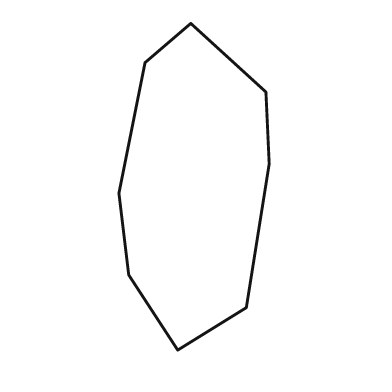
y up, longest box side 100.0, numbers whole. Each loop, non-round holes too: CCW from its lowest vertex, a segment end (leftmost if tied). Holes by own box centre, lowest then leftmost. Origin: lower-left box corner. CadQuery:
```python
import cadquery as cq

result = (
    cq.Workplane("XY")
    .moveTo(18.0, 0.0)
    .lineTo(39.0, 13.0)
    .lineTo(46.0, 57.0)
    .lineTo(45.0, 79.0)
    .lineTo(22.0, 100.0)
    .lineTo(8.0, 88.0)
    .lineTo(0.0, 48.0)
    .lineTo(3.0, 23.0)
    .close()
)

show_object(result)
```